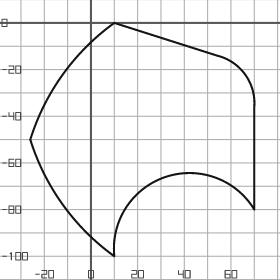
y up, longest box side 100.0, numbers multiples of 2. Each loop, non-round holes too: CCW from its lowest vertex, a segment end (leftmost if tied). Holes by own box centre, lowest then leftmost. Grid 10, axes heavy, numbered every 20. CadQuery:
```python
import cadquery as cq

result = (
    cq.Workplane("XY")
    .moveTo(10.0, -100.0)
    .threePointArc((32.0, -66.0), (70.0, -80.0))
    .lineTo(70.0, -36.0)
    .threePointArc((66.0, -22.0), (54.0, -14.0))
    .lineTo(10.0, 0.0)
    .threePointArc((-12.0, -22.0), (-26.0, -50.0))
    .threePointArc((-12.0, -78.0), (10.0, -100.0))
    .close()
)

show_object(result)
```